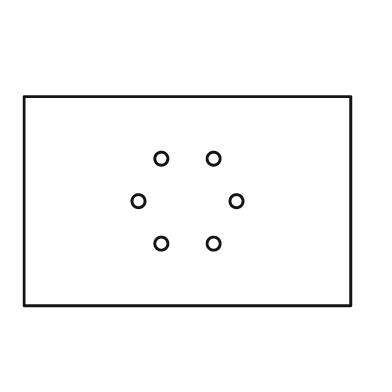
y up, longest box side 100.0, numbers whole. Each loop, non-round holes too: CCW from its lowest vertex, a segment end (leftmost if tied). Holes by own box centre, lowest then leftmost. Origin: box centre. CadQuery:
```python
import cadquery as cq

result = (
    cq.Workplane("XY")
    .moveTo(-50.0, -32.0)
    .lineTo(50.0, -32.0)
    .lineTo(50.0, 32.0)
    .lineTo(-50.0, 32.0)
    .close()
    .moveTo(-8.0, -13.0)
    .circle(2.0)
    .moveTo(8.0, -13.0)
    .circle(2.0)
    .moveTo(-15.0, 0.0)
    .circle(2.0)
    .moveTo(15.0, 0.0)
    .circle(2.0)
    .moveTo(-8.0, 13.0)
    .circle(2.0)
    .moveTo(8.0, 13.0)
    .circle(2.0)
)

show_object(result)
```